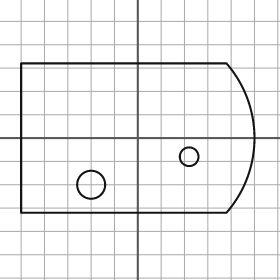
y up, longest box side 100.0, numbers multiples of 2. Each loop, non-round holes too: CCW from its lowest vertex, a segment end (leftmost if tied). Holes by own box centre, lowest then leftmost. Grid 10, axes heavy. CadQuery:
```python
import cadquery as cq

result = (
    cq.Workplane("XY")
    .moveTo(-50.0, -32.0)
    .lineTo(38.0, -32.0)
    .threePointArc((50.0, 0.0), (38.0, 32.0))
    .lineTo(-50.0, 32.0)
    .close()
    .moveTo(-20.0, -20.0)
    .circle(6.0)
    .moveTo(22.0, -8.0)
    .circle(4.0)
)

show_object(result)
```